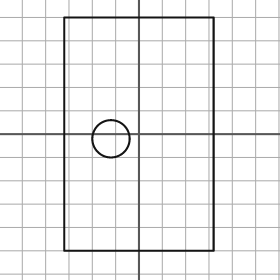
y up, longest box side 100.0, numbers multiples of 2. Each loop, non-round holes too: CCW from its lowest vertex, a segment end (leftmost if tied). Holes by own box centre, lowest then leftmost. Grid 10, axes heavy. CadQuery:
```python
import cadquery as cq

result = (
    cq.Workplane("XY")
    .moveTo(-32.0, -50.0)
    .lineTo(32.0, -50.0)
    .lineTo(32.0, 50.0)
    .lineTo(-32.0, 50.0)
    .close()
    .moveTo(-12.0, -2.0)
    .circle(8.0)
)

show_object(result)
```